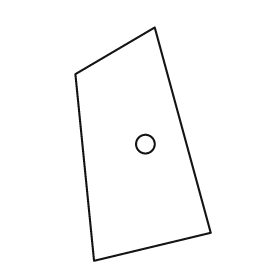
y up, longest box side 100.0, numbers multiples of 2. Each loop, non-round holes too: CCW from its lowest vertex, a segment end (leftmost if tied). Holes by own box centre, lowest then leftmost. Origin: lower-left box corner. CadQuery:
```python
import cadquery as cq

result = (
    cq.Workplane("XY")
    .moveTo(8.0, 0.0)
    .lineTo(58.0, 12.0)
    .lineTo(34.0, 100.0)
    .lineTo(0.0, 80.0)
    .close()
    .moveTo(30.0, 50.0)
    .circle(4.0)
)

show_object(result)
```